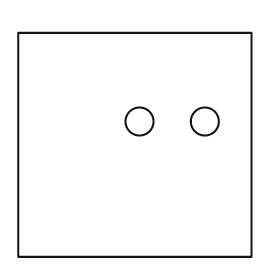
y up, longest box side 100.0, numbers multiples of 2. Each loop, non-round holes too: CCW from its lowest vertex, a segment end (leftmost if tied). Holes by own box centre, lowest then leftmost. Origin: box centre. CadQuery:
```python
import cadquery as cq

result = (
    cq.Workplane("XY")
    .moveTo(-50.0, -48.0)
    .lineTo(50.0, -48.0)
    .lineTo(50.0, 48.0)
    .lineTo(-50.0, 48.0)
    .close()
    .moveTo(2.0, 10.0)
    .circle(6.0)
    .moveTo(30.0, 10.0)
    .circle(6.0)
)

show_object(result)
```